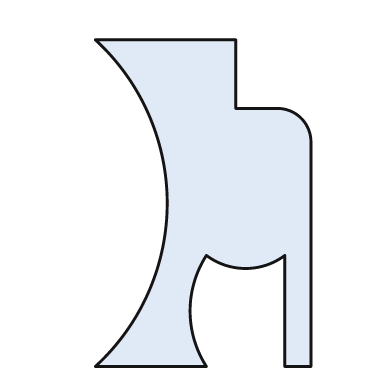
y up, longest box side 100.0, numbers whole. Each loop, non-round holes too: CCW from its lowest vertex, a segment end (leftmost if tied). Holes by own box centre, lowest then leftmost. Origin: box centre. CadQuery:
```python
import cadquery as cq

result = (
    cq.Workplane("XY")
    .moveTo(-33.0, -50.0)
    .lineTo(1.0, -50.0)
    .threePointArc((-4.0, -33.0), (1.0, -16.0))
    .threePointArc((13.0, -20.0), (25.0, -16.0))
    .lineTo(25.0, -50.0)
    .lineTo(33.0, -50.0)
    .lineTo(33.0, 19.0)
    .threePointArc((30.0, 26.0), (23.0, 29.0))
    .lineTo(10.0, 29.0)
    .lineTo(10.0, 50.0)
    .lineTo(-33.0, 50.0)
    .threePointArc((-11.0, 0.0), (-33.0, -50.0))
    .close()
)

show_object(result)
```